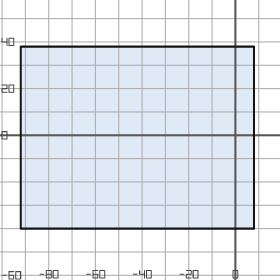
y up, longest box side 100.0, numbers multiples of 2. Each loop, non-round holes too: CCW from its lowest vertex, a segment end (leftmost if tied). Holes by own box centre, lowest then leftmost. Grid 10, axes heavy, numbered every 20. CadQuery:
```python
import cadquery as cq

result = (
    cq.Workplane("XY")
    .moveTo(-92.0, -40.0)
    .lineTo(8.0, -40.0)
    .lineTo(8.0, 38.0)
    .lineTo(-92.0, 38.0)
    .close()
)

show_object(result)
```